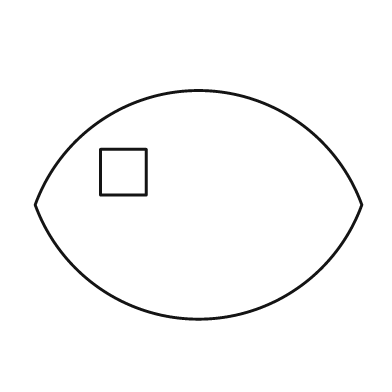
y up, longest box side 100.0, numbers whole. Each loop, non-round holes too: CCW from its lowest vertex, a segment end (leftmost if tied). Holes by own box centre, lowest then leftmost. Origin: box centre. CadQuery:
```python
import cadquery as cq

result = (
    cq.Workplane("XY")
    .moveTo(-50.0, 0.0)
    .threePointArc((0.0, -35.0), (50.0, 0.0))
    .threePointArc((0.0, 35.0), (-50.0, 0.0))
    .close()
    .moveTo(-30.0, 3.0)
    .lineTo(-16.0, 3.0)
    .lineTo(-16.0, 17.0)
    .lineTo(-30.0, 17.0)
    .close()
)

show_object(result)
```